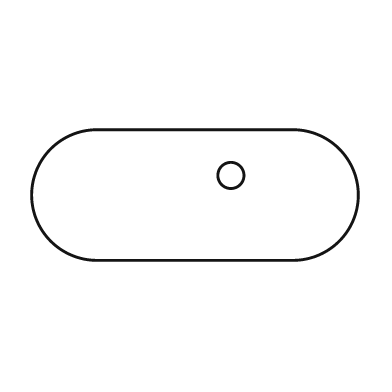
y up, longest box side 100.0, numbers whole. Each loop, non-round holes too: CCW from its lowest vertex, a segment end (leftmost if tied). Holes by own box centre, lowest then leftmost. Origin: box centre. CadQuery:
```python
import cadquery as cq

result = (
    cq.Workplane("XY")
    .moveTo(-30.0, -20.0)
    .lineTo(30.0, -20.0)
    .threePointArc((50.0, 0.0), (30.0, 20.0))
    .lineTo(-30.0, 20.0)
    .threePointArc((-50.0, 0.0), (-30.0, -20.0))
    .close()
    .moveTo(11.0, 6.0)
    .circle(4.0)
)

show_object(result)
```